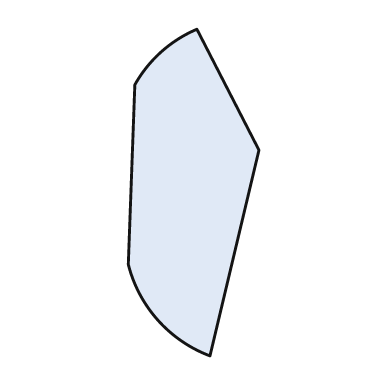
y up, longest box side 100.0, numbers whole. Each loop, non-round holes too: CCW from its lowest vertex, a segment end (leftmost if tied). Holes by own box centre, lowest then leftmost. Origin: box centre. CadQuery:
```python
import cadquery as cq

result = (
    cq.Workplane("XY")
    .moveTo(5.0, -50.0)
    .lineTo(20.0, 13.0)
    .lineTo(1.0, 50.0)
    .threePointArc((-10.0, 43.0), (-18.0, 33.0))
    .lineTo(-20.0, -22.0)
    .threePointArc((-11.0, -39.0), (5.0, -50.0))
    .close()
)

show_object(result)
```